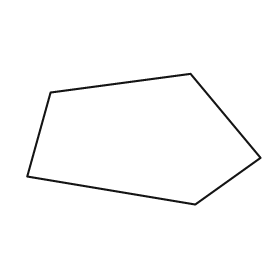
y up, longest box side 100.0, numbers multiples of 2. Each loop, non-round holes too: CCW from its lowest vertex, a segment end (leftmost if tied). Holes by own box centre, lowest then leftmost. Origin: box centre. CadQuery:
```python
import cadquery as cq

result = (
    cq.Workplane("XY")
    .moveTo(22.0, -28.0)
    .lineTo(50.0, -8.0)
    .lineTo(20.0, 28.0)
    .lineTo(-40.0, 20.0)
    .lineTo(-50.0, -16.0)
    .close()
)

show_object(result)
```